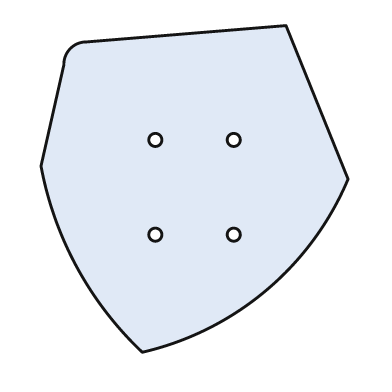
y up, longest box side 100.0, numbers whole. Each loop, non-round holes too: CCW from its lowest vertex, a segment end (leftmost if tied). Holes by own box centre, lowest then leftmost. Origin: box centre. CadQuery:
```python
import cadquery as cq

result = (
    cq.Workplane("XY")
    .moveTo(-16.0, -50.0)
    .threePointArc((22.0, -31.0), (47.0, 3.0))
    .lineTo(28.0, 50.0)
    .lineTo(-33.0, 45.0)
    .threePointArc((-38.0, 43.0), (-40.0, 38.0))
    .lineTo(-47.0, 7.0)
    .threePointArc((-36.0, -24.0), (-16.0, -50.0))
    .close()
    .moveTo(-12.0, -14.0)
    .circle(2.0)
    .moveTo(12.0, -14.0)
    .circle(2.0)
    .moveTo(-12.0, 15.0)
    .circle(2.0)
    .moveTo(12.0, 15.0)
    .circle(2.0)
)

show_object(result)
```